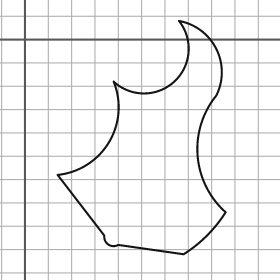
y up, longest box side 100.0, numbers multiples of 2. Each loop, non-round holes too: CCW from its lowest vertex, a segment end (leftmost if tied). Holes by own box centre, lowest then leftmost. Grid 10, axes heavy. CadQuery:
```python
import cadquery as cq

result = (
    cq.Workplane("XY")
    .moveTo(68.0, -92.0)
    .threePointArc((78.0, -84.0), (86.0, -74.0))
    .threePointArc((74.0, -50.0), (82.0, -24.0))
    .threePointArc((82.0, -4.0), (66.0, 8.0))
    .threePointArc((64.0, -18.0), (38.0, -18.0))
    .threePointArc((36.0, -44.0), (14.0, -58.0))
    .lineTo(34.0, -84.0)
    .threePointArc((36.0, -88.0), (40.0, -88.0))
    .close()
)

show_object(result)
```